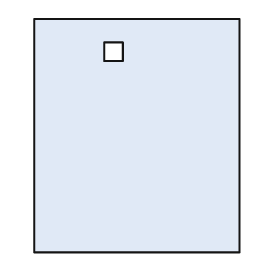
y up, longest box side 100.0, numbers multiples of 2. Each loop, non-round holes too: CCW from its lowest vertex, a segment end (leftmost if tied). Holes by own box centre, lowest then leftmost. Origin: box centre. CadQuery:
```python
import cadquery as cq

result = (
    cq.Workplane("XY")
    .moveTo(-44.0, -50.0)
    .lineTo(44.0, -50.0)
    .lineTo(44.0, 50.0)
    .lineTo(-44.0, 50.0)
    .close()
    .moveTo(-14.0, 32.0)
    .lineTo(-6.0, 32.0)
    .lineTo(-6.0, 40.0)
    .lineTo(-14.0, 40.0)
    .close()
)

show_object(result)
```